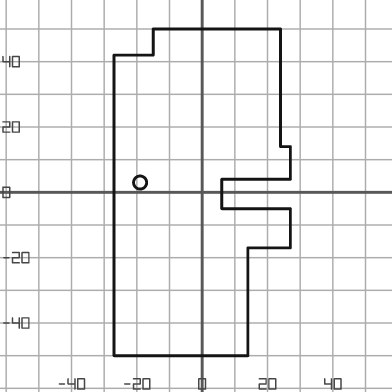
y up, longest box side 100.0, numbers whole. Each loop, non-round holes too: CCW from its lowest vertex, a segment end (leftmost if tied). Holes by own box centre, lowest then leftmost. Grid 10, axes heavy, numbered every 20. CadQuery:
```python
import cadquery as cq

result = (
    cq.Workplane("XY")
    .moveTo(-27.0, -50.0)
    .lineTo(14.0, -50.0)
    .lineTo(14.0, -17.0)
    .lineTo(27.0, -17.0)
    .lineTo(27.0, -5.0)
    .lineTo(6.0, -5.0)
    .lineTo(6.0, 4.0)
    .lineTo(27.0, 4.0)
    .lineTo(27.0, 14.0)
    .lineTo(24.0, 14.0)
    .lineTo(24.0, 50.0)
    .lineTo(-15.0, 50.0)
    .lineTo(-15.0, 42.0)
    .lineTo(-27.0, 42.0)
    .close()
    .moveTo(-19.0, 3.0)
    .circle(2.0)
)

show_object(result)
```